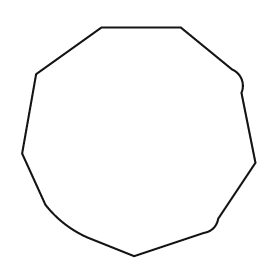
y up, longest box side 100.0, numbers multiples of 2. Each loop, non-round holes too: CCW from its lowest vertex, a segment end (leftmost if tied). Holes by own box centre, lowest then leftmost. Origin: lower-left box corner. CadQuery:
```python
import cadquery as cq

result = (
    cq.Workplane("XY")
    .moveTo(48.0, 0.0)
    .lineTo(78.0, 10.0)
    .threePointArc((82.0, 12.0), (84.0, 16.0))
    .lineTo(100.0, 40.0)
    .lineTo(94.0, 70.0)
    .threePointArc((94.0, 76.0), (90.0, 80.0))
    .lineTo(68.0, 98.0)
    .lineTo(34.0, 98.0)
    .lineTo(6.0, 78.0)
    .lineTo(0.0, 44.0)
    .lineTo(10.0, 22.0)
    .threePointArc((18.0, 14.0), (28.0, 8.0))
    .close()
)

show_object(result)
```